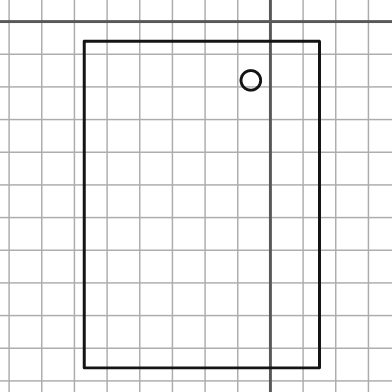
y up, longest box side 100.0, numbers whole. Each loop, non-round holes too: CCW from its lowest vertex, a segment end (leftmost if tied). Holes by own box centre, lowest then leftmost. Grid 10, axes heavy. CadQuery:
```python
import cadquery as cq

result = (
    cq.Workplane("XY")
    .moveTo(-57.0, -106.0)
    .lineTo(15.0, -106.0)
    .lineTo(15.0, -6.0)
    .lineTo(-57.0, -6.0)
    .close()
    .moveTo(-6.0, -18.0)
    .circle(3.0)
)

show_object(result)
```